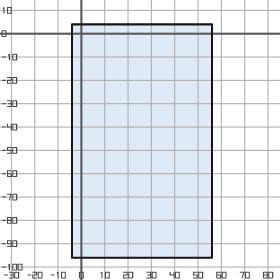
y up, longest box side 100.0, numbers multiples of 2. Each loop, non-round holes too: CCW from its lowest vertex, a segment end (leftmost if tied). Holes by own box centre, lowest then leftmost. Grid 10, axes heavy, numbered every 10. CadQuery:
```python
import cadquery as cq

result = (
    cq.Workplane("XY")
    .moveTo(-4.0, -96.0)
    .lineTo(56.0, -96.0)
    .lineTo(56.0, 4.0)
    .lineTo(-4.0, 4.0)
    .close()
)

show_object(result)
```